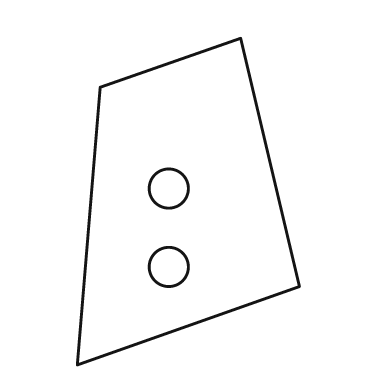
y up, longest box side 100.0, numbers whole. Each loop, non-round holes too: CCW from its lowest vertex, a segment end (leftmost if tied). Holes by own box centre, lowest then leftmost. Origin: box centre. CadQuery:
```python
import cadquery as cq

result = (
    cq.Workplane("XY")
    .moveTo(-34.0, -50.0)
    .lineTo(34.0, -26.0)
    .lineTo(16.0, 50.0)
    .lineTo(-27.0, 35.0)
    .close()
    .moveTo(-6.0, -20.0)
    .circle(6.0)
    .moveTo(-6.0, 4.0)
    .circle(6.0)
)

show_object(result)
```